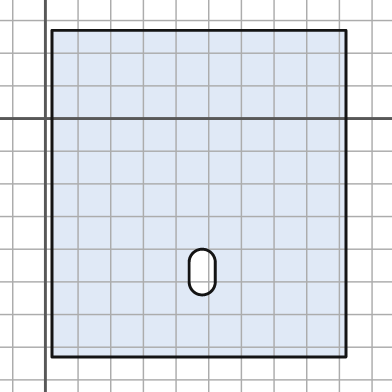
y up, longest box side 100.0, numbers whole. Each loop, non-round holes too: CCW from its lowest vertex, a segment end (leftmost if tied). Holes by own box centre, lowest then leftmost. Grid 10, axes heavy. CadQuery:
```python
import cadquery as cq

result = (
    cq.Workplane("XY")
    .moveTo(2.0, -73.0)
    .lineTo(92.0, -73.0)
    .lineTo(92.0, 27.0)
    .lineTo(2.0, 27.0)
    .close()
    .moveTo(44.0, -50.0)
    .threePointArc((48.0, -54.0), (52.0, -50.0))
    .lineTo(52.0, -44.0)
    .threePointArc((48.0, -40.0), (44.0, -44.0))
    .close()
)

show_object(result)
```